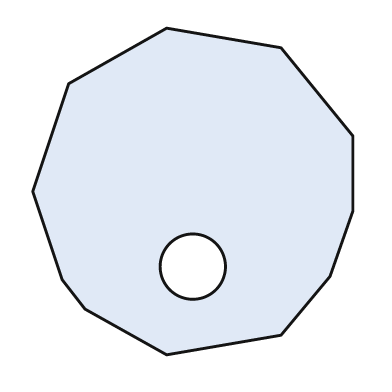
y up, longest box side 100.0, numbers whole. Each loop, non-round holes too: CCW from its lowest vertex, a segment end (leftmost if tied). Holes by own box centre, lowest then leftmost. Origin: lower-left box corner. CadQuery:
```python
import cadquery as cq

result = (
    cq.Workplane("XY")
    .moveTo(41.0, 0.0)
    .lineTo(76.0, 6.0)
    .lineTo(91.0, 24.0)
    .lineTo(98.0, 44.0)
    .lineTo(98.0, 67.0)
    .lineTo(76.0, 94.0)
    .lineTo(41.0, 100.0)
    .lineTo(11.0, 83.0)
    .lineTo(0.0, 50.0)
    .lineTo(9.0, 23.0)
    .lineTo(16.0, 14.0)
    .close()
    .moveTo(49.0, 27.0)
    .circle(10.0)
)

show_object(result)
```